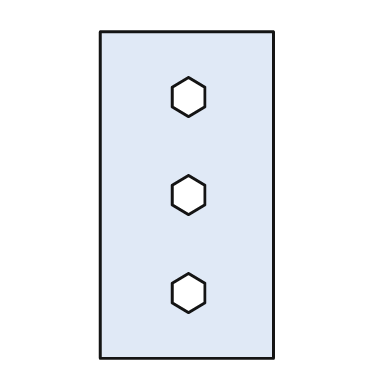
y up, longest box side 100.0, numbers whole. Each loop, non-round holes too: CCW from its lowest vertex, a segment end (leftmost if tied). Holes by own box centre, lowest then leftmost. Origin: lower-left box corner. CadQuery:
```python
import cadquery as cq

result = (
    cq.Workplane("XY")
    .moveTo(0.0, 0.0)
    .lineTo(53.0, 0.0)
    .lineTo(53.0, 100.0)
    .lineTo(0.0, 100.0)
    .close()
    .moveTo(27.0, 14.0)
    .lineTo(32.0, 17.0)
    .lineTo(32.0, 23.0)
    .lineTo(27.0, 26.0)
    .lineTo(22.0, 23.0)
    .lineTo(22.0, 17.0)
    .close()
    .moveTo(27.0, 44.0)
    .lineTo(32.0, 47.0)
    .lineTo(32.0, 53.0)
    .lineTo(27.0, 56.0)
    .lineTo(22.0, 53.0)
    .lineTo(22.0, 47.0)
    .close()
    .moveTo(27.0, 74.0)
    .lineTo(32.0, 77.0)
    .lineTo(32.0, 83.0)
    .lineTo(27.0, 86.0)
    .lineTo(22.0, 83.0)
    .lineTo(22.0, 77.0)
    .close()
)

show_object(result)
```